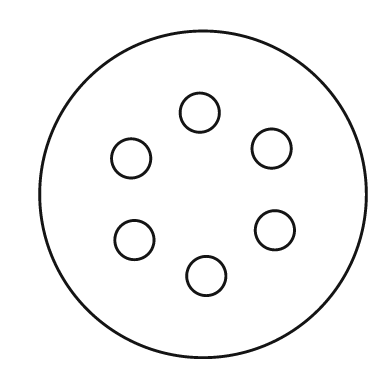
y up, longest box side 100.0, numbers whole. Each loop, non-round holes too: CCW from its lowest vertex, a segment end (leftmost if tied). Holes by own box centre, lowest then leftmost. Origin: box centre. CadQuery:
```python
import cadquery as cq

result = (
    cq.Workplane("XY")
    .moveTo(0.0, 0.0)
    .circle(50.0)
    .moveTo(1.0, -25.0)
    .circle(6.0)
    .moveTo(-21.0, -14.0)
    .circle(6.0)
    .moveTo(22.0, -11.0)
    .circle(6.0)
    .moveTo(-22.0, 11.0)
    .circle(6.0)
    .moveTo(21.0, 14.0)
    .circle(6.0)
    .moveTo(-1.0, 25.0)
    .circle(6.0)
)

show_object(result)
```